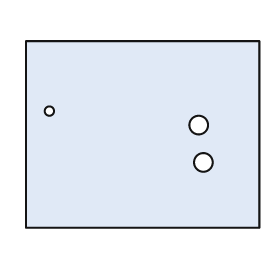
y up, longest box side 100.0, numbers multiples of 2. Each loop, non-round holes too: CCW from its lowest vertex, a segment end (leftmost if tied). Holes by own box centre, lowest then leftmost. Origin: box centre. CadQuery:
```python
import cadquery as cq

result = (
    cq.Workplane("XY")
    .moveTo(-50.0, -40.0)
    .lineTo(50.0, -40.0)
    .lineTo(50.0, 40.0)
    .lineTo(-50.0, 40.0)
    .close()
    .moveTo(26.0, -12.0)
    .circle(4.0)
    .moveTo(24.0, 4.0)
    .circle(4.0)
    .moveTo(-40.0, 10.0)
    .circle(2.0)
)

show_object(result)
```